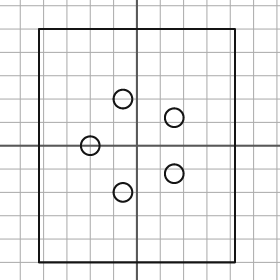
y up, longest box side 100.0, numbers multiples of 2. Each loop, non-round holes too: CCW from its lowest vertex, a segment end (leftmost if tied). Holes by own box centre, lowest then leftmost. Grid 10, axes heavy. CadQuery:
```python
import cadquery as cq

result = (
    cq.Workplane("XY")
    .moveTo(-42.0, -50.0)
    .lineTo(42.0, -50.0)
    .lineTo(42.0, 50.0)
    .lineTo(-42.0, 50.0)
    .close()
    .moveTo(-6.0, -20.0)
    .circle(4.0)
    .moveTo(16.0, -12.0)
    .circle(4.0)
    .moveTo(-20.0, 0.0)
    .circle(4.0)
    .moveTo(16.0, 12.0)
    .circle(4.0)
    .moveTo(-6.0, 20.0)
    .circle(4.0)
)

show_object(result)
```